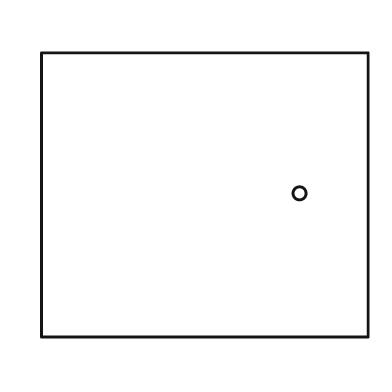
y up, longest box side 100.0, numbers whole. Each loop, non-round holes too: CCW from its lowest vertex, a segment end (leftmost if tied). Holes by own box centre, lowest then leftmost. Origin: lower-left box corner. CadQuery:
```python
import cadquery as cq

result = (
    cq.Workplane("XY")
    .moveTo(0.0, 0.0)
    .lineTo(100.0, 0.0)
    .lineTo(100.0, 87.0)
    .lineTo(0.0, 87.0)
    .close()
    .moveTo(79.0, 44.0)
    .circle(2.0)
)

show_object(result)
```